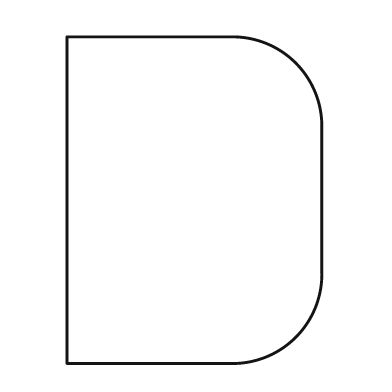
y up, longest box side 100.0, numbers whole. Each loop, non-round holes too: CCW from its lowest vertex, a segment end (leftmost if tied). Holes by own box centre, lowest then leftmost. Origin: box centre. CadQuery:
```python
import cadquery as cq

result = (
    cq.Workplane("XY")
    .moveTo(-39.0, -50.0)
    .lineTo(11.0, -50.0)
    .threePointArc((31.0, -42.0), (39.0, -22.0))
    .lineTo(39.0, 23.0)
    .threePointArc((31.0, 42.0), (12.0, 50.0))
    .lineTo(-39.0, 50.0)
    .close()
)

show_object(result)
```